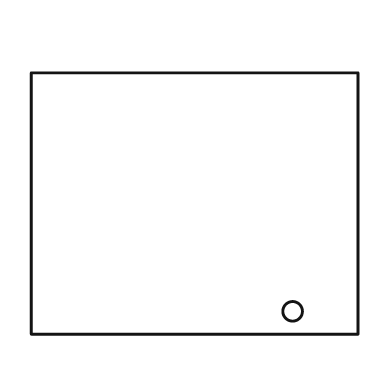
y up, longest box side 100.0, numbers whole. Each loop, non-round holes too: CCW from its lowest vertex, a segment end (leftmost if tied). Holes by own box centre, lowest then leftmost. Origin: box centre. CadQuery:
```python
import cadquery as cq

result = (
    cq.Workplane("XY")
    .moveTo(-50.0, -40.0)
    .lineTo(50.0, -40.0)
    .lineTo(50.0, 40.0)
    .lineTo(-50.0, 40.0)
    .close()
    .moveTo(30.0, -33.0)
    .circle(3.0)
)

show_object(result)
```